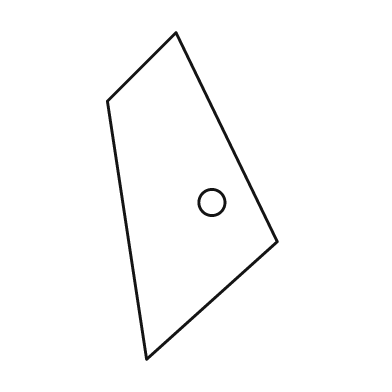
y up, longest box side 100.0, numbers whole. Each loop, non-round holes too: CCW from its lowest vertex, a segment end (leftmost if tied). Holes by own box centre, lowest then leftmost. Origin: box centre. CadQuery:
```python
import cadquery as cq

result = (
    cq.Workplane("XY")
    .moveTo(-14.0, -50.0)
    .lineTo(26.0, -14.0)
    .lineTo(-5.0, 50.0)
    .lineTo(-26.0, 29.0)
    .close()
    .moveTo(6.0, -2.0)
    .circle(4.0)
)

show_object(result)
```